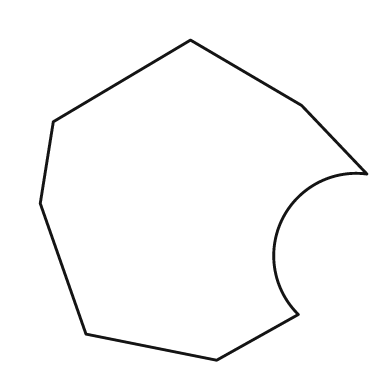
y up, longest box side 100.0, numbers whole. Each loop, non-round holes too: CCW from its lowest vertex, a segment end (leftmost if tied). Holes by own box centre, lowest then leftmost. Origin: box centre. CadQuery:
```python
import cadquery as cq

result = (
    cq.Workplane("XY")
    .moveTo(4.0, -49.0)
    .lineTo(29.0, -35.0)
    .threePointArc((24.0, -6.0), (50.0, 8.0))
    .lineTo(30.0, 29.0)
    .lineTo(-4.0, 49.0)
    .lineTo(-46.0, 24.0)
    .lineTo(-50.0, -1.0)
    .lineTo(-36.0, -41.0)
    .close()
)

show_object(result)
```